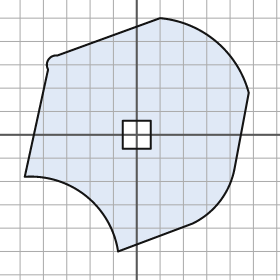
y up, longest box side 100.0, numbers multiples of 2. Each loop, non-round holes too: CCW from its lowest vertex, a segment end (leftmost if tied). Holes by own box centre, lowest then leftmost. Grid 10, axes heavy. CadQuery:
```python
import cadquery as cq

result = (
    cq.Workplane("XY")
    .moveTo(-8.0, -50.0)
    .lineTo(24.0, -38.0)
    .threePointArc((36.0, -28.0), (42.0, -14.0))
    .lineTo(48.0, 18.0)
    .threePointArc((34.0, 40.0), (10.0, 50.0))
    .lineTo(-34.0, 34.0)
    .threePointArc((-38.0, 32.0), (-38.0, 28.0))
    .lineTo(-48.0, -18.0)
    .threePointArc((-22.0, -26.0), (-8.0, -50.0))
    .close()
    .moveTo(-6.0, -6.0)
    .lineTo(6.0, -6.0)
    .lineTo(6.0, 6.0)
    .lineTo(-6.0, 6.0)
    .close()
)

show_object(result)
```